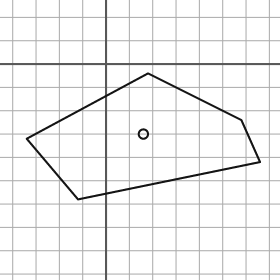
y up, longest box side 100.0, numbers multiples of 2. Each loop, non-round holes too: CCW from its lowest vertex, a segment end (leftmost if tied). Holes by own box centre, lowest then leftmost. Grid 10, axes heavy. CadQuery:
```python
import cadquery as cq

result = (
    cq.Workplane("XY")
    .moveTo(-12.0, -58.0)
    .lineTo(66.0, -42.0)
    .lineTo(58.0, -24.0)
    .lineTo(18.0, -4.0)
    .lineTo(-34.0, -32.0)
    .close()
    .moveTo(16.0, -30.0)
    .circle(2.0)
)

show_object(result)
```